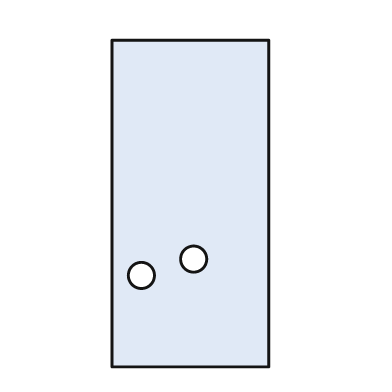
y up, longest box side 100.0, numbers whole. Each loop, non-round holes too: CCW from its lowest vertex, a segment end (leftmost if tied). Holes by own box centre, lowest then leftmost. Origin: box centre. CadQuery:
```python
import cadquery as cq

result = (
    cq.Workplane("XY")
    .moveTo(-24.0, -50.0)
    .lineTo(24.0, -50.0)
    .lineTo(24.0, 50.0)
    .lineTo(-24.0, 50.0)
    .close()
    .moveTo(-15.0, -22.0)
    .circle(4.0)
    .moveTo(1.0, -17.0)
    .circle(4.0)
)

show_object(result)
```